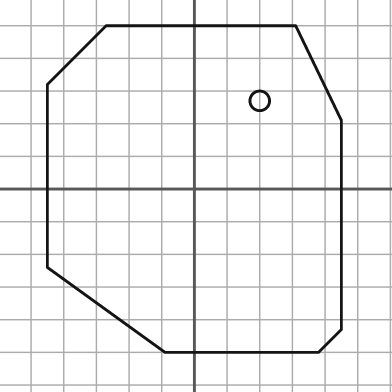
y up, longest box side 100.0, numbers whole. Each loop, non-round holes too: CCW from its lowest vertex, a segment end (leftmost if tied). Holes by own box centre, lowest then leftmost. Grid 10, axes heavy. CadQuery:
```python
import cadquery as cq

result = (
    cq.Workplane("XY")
    .moveTo(-9.0, -50.0)
    .lineTo(38.0, -50.0)
    .lineTo(45.0, -43.0)
    .lineTo(45.0, 21.0)
    .lineTo(31.0, 50.0)
    .lineTo(-27.0, 50.0)
    .lineTo(-45.0, 32.0)
    .lineTo(-45.0, -24.0)
    .close()
    .moveTo(20.0, 27.0)
    .circle(3.0)
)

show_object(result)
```